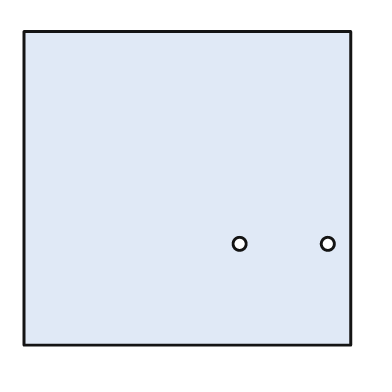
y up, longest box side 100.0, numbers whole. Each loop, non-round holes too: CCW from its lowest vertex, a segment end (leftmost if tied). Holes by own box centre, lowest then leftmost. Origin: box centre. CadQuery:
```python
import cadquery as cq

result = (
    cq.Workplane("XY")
    .moveTo(-50.0, -48.0)
    .lineTo(50.0, -48.0)
    .lineTo(50.0, 48.0)
    .lineTo(-50.0, 48.0)
    .close()
    .moveTo(16.0, -17.0)
    .circle(2.0)
    .moveTo(43.0, -17.0)
    .circle(2.0)
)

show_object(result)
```